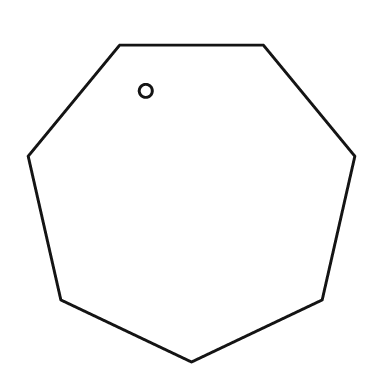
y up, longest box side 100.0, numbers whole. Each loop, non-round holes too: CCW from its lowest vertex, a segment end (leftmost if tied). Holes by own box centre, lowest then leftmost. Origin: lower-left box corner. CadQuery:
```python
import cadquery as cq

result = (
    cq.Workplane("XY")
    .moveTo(50.0, 0.0)
    .lineTo(90.0, 19.0)
    .lineTo(100.0, 63.0)
    .lineTo(72.0, 97.0)
    .lineTo(28.0, 97.0)
    .lineTo(0.0, 63.0)
    .lineTo(10.0, 19.0)
    .close()
    .moveTo(36.0, 83.0)
    .circle(2.0)
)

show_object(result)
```